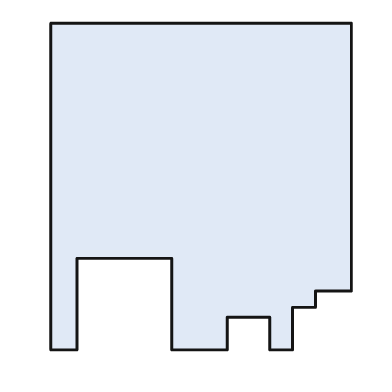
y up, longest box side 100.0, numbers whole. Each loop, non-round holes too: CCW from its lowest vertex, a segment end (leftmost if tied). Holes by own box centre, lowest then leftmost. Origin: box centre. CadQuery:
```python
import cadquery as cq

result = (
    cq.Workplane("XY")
    .moveTo(-46.0, -50.0)
    .lineTo(-38.0, -50.0)
    .lineTo(-38.0, -22.0)
    .lineTo(-9.0, -22.0)
    .lineTo(-9.0, -50.0)
    .lineTo(8.0, -50.0)
    .lineTo(8.0, -40.0)
    .lineTo(21.0, -40.0)
    .lineTo(21.0, -50.0)
    .lineTo(28.0, -50.0)
    .lineTo(28.0, -37.0)
    .lineTo(35.0, -37.0)
    .lineTo(35.0, -32.0)
    .lineTo(46.0, -32.0)
    .lineTo(46.0, 50.0)
    .lineTo(-46.0, 50.0)
    .close()
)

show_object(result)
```